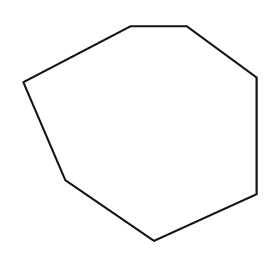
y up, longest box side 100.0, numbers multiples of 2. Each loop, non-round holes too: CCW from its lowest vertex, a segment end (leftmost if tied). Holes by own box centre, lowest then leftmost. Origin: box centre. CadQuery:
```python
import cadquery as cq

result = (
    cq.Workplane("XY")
    .moveTo(6.0, -46.0)
    .lineTo(50.0, -26.0)
    .lineTo(50.0, 24.0)
    .lineTo(20.0, 46.0)
    .lineTo(-4.0, 46.0)
    .lineTo(-50.0, 22.0)
    .lineTo(-32.0, -20.0)
    .close()
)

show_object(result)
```